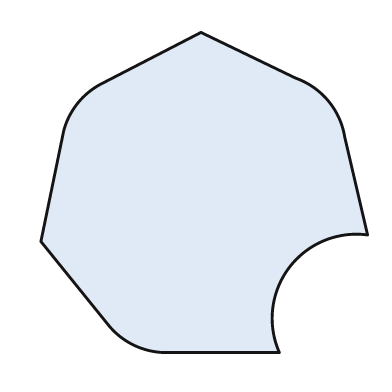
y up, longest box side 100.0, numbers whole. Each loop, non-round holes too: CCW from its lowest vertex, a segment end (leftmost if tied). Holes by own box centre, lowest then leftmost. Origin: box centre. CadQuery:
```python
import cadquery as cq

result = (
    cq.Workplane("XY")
    .moveTo(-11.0, -49.0)
    .lineTo(23.0, -49.0)
    .threePointArc((26.0, -23.0), (50.0, -13.0))
    .lineTo(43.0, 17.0)
    .threePointArc((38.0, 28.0), (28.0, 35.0))
    .lineTo(-1.0, 49.0)
    .lineTo(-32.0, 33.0)
    .threePointArc((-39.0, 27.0), (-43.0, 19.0))
    .lineTo(-50.0, -15.0)
    .lineTo(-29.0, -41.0)
    .threePointArc((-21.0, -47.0), (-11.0, -49.0))
    .close()
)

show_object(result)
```